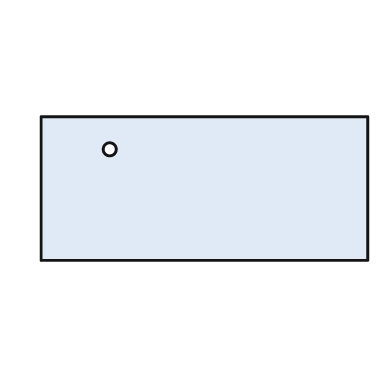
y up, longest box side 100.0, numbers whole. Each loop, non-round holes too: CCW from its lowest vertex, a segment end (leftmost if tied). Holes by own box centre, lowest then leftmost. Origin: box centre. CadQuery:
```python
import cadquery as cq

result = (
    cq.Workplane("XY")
    .moveTo(-50.0, -22.0)
    .lineTo(50.0, -22.0)
    .lineTo(50.0, 22.0)
    .lineTo(-50.0, 22.0)
    .close()
    .moveTo(-29.0, 12.0)
    .circle(2.0)
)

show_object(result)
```